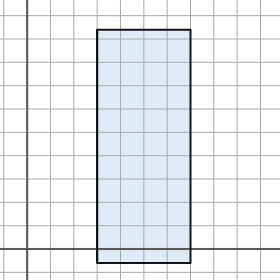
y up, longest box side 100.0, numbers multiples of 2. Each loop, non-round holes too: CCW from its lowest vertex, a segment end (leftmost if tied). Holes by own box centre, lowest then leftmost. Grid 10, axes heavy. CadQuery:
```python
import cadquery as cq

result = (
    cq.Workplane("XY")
    .moveTo(30.0, -6.0)
    .lineTo(70.0, -6.0)
    .lineTo(70.0, 94.0)
    .lineTo(30.0, 94.0)
    .close()
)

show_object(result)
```